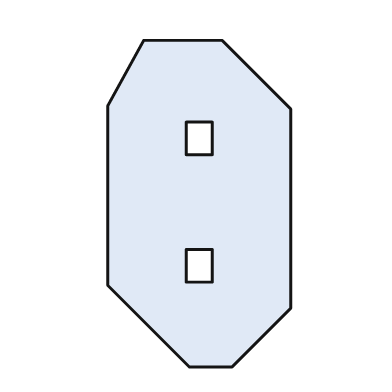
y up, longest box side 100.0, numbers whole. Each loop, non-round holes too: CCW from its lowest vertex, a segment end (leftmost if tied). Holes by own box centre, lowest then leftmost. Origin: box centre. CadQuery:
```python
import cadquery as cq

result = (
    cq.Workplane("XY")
    .moveTo(-3.0, -50.0)
    .lineTo(10.0, -50.0)
    .lineTo(28.0, -32.0)
    .lineTo(28.0, 29.0)
    .lineTo(7.0, 50.0)
    .lineTo(-17.0, 50.0)
    .lineTo(-28.0, 30.0)
    .lineTo(-28.0, -25.0)
    .close()
    .moveTo(-4.0, -24.0)
    .lineTo(4.0, -24.0)
    .lineTo(4.0, -14.0)
    .lineTo(-4.0, -14.0)
    .close()
    .moveTo(-4.0, 15.0)
    .lineTo(4.0, 15.0)
    .lineTo(4.0, 25.0)
    .lineTo(-4.0, 25.0)
    .close()
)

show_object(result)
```